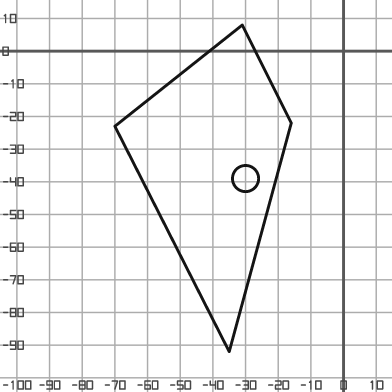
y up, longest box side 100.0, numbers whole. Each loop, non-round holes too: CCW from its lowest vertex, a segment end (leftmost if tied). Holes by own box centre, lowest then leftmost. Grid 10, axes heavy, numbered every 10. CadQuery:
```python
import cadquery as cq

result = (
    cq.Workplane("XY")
    .moveTo(-35.0, -92.0)
    .lineTo(-16.0, -22.0)
    .lineTo(-31.0, 8.0)
    .lineTo(-70.0, -23.0)
    .close()
    .moveTo(-30.0, -39.0)
    .circle(4.0)
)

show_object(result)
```